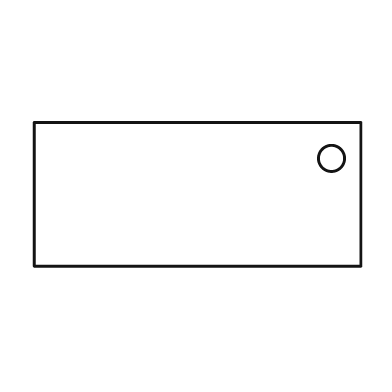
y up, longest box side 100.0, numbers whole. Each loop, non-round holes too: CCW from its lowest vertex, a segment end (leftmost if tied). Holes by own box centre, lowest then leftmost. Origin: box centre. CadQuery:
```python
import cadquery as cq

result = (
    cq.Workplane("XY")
    .moveTo(-50.0, -22.0)
    .lineTo(50.0, -22.0)
    .lineTo(50.0, 22.0)
    .lineTo(-50.0, 22.0)
    .close()
    .moveTo(41.0, 11.0)
    .circle(4.0)
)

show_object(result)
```